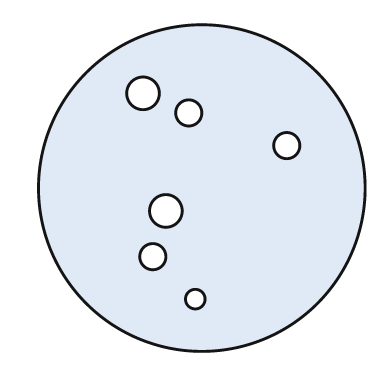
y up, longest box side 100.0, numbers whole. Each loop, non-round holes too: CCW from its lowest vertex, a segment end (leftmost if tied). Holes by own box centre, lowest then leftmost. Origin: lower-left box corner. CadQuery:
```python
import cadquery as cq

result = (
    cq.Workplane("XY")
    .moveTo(50.0, 50.0)
    .circle(50.0)
    .moveTo(48.0, 16.0)
    .circle(3.0)
    .moveTo(35.0, 29.0)
    .circle(4.0)
    .moveTo(39.0, 43.0)
    .circle(5.0)
    .moveTo(76.0, 63.0)
    .circle(4.0)
    .moveTo(46.0, 73.0)
    .circle(4.0)
    .moveTo(32.0, 79.0)
    .circle(5.0)
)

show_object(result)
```